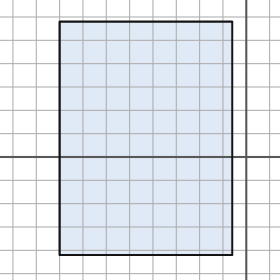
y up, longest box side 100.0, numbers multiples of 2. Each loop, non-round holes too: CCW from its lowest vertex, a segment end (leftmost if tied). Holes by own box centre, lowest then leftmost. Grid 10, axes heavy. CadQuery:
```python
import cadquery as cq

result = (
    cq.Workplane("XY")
    .moveTo(-80.0, -42.0)
    .lineTo(-6.0, -42.0)
    .lineTo(-6.0, 58.0)
    .lineTo(-80.0, 58.0)
    .close()
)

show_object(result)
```